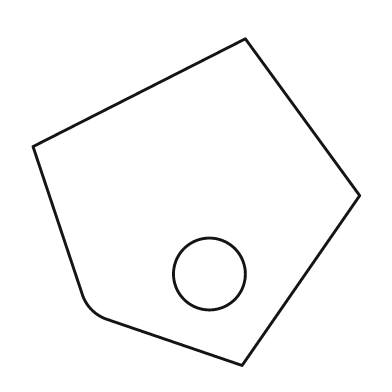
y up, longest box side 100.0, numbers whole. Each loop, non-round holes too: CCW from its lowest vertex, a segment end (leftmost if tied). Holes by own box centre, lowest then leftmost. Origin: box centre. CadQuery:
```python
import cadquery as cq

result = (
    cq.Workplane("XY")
    .moveTo(14.0, -50.0)
    .lineTo(50.0, 2.0)
    .lineTo(15.0, 50.0)
    .lineTo(-50.0, 17.0)
    .lineTo(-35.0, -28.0)
    .threePointArc((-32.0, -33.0), (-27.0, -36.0))
    .close()
    .moveTo(4.0, -22.0)
    .circle(11.0)
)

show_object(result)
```